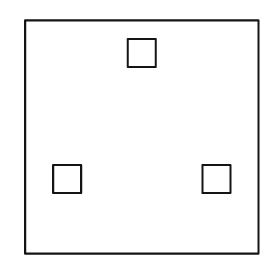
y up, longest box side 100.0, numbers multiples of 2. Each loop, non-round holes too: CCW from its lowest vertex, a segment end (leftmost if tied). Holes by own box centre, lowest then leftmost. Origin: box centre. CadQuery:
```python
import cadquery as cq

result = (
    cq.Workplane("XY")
    .moveTo(-50.0, -50.0)
    .lineTo(50.0, -50.0)
    .lineTo(50.0, 50.0)
    .lineTo(-50.0, 50.0)
    .close()
    .moveTo(-38.0, -24.0)
    .lineTo(-26.0, -24.0)
    .lineTo(-26.0, -12.0)
    .lineTo(-38.0, -12.0)
    .close()
    .moveTo(26.0, -24.0)
    .lineTo(38.0, -24.0)
    .lineTo(38.0, -12.0)
    .lineTo(26.0, -12.0)
    .close()
    .moveTo(-6.0, 30.0)
    .lineTo(6.0, 30.0)
    .lineTo(6.0, 42.0)
    .lineTo(-6.0, 42.0)
    .close()
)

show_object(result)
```